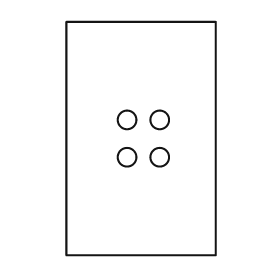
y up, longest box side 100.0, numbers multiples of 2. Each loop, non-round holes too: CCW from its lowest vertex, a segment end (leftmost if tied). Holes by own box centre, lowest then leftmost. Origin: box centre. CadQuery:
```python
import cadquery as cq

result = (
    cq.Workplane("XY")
    .moveTo(-32.0, -50.0)
    .lineTo(32.0, -50.0)
    .lineTo(32.0, 50.0)
    .lineTo(-32.0, 50.0)
    .close()
    .moveTo(-6.0, -8.0)
    .circle(4.0)
    .moveTo(8.0, -8.0)
    .circle(4.0)
    .moveTo(-6.0, 8.0)
    .circle(4.0)
    .moveTo(8.0, 8.0)
    .circle(4.0)
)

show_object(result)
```